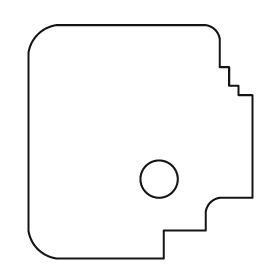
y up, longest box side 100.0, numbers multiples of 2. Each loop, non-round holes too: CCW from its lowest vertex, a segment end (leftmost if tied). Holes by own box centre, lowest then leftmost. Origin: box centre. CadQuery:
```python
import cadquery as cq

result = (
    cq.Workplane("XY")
    .moveTo(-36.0, -50.0)
    .lineTo(10.0, -50.0)
    .lineTo(10.0, -38.0)
    .lineTo(28.0, -38.0)
    .lineTo(28.0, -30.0)
    .threePointArc((30.0, -26.0), (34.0, -24.0))
    .lineTo(48.0, -24.0)
    .lineTo(48.0, 20.0)
    .lineTo(42.0, 20.0)
    .lineTo(42.0, 24.0)
    .lineTo(38.0, 24.0)
    .lineTo(38.0, 32.0)
    .lineTo(34.0, 32.0)
    .lineTo(34.0, 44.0)
    .threePointArc((32.0, 48.0), (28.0, 50.0))
    .lineTo(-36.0, 50.0)
    .threePointArc((-44.0, 46.0), (-48.0, 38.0))
    .lineTo(-48.0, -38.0)
    .threePointArc((-44.0, -46.0), (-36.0, -50.0))
    .close()
    .moveTo(8.0, -16.0)
    .circle(8.0)
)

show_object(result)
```